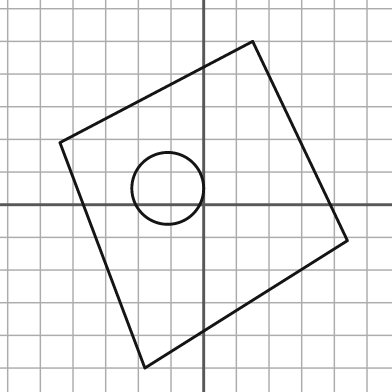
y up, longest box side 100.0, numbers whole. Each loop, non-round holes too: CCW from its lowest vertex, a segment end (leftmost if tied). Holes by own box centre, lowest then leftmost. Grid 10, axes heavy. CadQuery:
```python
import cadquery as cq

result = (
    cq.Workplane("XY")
    .moveTo(-18.0, -50.0)
    .lineTo(44.0, -11.0)
    .lineTo(15.0, 50.0)
    .lineTo(-44.0, 19.0)
    .close()
    .moveTo(-11.0, 5.0)
    .circle(11.0)
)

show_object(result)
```